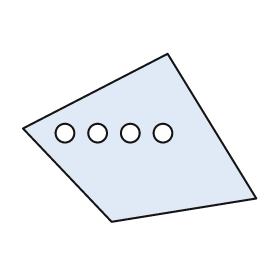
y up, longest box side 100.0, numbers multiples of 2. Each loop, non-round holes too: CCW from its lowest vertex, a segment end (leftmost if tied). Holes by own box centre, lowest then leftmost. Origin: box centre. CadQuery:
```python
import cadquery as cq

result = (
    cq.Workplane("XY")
    .moveTo(-12.0, -36.0)
    .lineTo(50.0, -26.0)
    .lineTo(12.0, 36.0)
    .lineTo(-50.0, 4.0)
    .close()
    .moveTo(-32.0, 2.0)
    .circle(4.0)
    .moveTo(-18.0, 2.0)
    .circle(4.0)
    .moveTo(-4.0, 2.0)
    .circle(4.0)
    .moveTo(10.0, 2.0)
    .circle(4.0)
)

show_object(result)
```